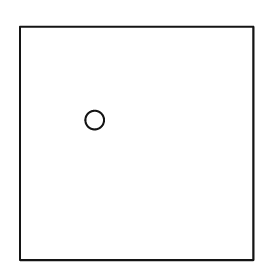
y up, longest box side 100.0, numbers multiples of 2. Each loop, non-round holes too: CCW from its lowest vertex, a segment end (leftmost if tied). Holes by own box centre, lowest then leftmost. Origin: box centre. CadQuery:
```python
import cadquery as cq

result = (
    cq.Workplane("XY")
    .moveTo(-50.0, -50.0)
    .lineTo(50.0, -50.0)
    .lineTo(50.0, 50.0)
    .lineTo(-50.0, 50.0)
    .close()
    .moveTo(-18.0, 10.0)
    .circle(4.0)
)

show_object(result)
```